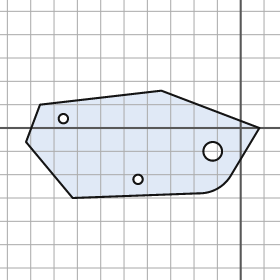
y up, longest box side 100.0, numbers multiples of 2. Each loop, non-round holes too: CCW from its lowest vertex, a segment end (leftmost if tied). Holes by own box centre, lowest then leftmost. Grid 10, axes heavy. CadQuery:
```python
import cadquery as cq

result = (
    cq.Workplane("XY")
    .moveTo(-72.0, -30.0)
    .lineTo(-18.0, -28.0)
    .threePointArc((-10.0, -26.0), (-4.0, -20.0))
    .lineTo(8.0, 0.0)
    .lineTo(-34.0, 16.0)
    .lineTo(-86.0, 10.0)
    .lineTo(-92.0, -6.0)
    .close()
    .moveTo(-44.0, -22.0)
    .circle(2.0)
    .moveTo(-12.0, -10.0)
    .circle(4.0)
    .moveTo(-76.0, 4.0)
    .circle(2.0)
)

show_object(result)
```